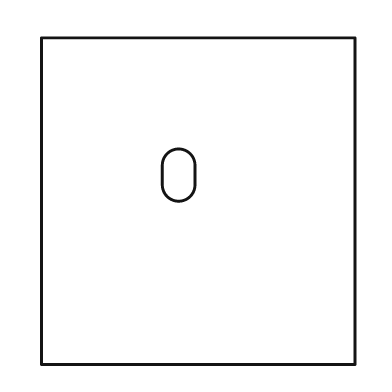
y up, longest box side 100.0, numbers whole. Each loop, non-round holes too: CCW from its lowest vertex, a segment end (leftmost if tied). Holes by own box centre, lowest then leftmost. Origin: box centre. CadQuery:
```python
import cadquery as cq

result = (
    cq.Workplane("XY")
    .moveTo(-48.0, -50.0)
    .lineTo(48.0, -50.0)
    .lineTo(48.0, 50.0)
    .lineTo(-48.0, 50.0)
    .close()
    .moveTo(-11.0, 5.0)
    .threePointArc((-6.0, 0.0), (-1.0, 5.0))
    .lineTo(-1.0, 11.0)
    .threePointArc((-6.0, 16.0), (-11.0, 11.0))
    .close()
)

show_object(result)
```